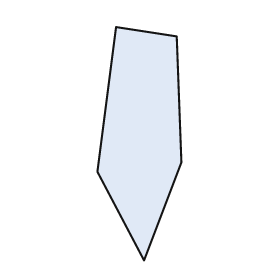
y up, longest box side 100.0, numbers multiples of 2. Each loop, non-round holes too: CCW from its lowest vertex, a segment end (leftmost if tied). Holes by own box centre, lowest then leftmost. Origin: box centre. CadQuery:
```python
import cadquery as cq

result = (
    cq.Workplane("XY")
    .moveTo(2.0, -50.0)
    .lineTo(18.0, -8.0)
    .lineTo(16.0, 46.0)
    .lineTo(-10.0, 50.0)
    .lineTo(-18.0, -12.0)
    .close()
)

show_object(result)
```